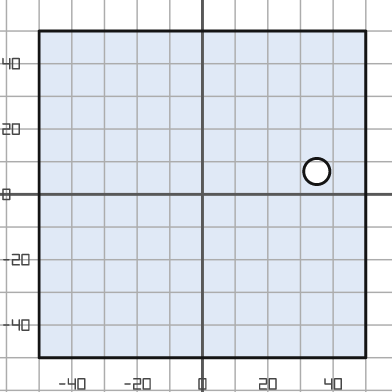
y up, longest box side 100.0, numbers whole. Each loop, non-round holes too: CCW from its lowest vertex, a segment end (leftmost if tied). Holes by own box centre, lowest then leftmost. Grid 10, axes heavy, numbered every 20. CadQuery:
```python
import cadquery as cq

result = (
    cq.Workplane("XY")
    .moveTo(-50.0, -50.0)
    .lineTo(50.0, -50.0)
    .lineTo(50.0, 50.0)
    .lineTo(-50.0, 50.0)
    .close()
    .moveTo(35.0, 7.0)
    .circle(4.0)
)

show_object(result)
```